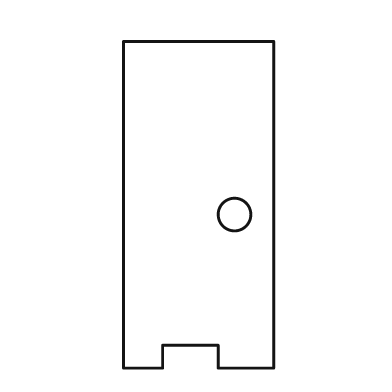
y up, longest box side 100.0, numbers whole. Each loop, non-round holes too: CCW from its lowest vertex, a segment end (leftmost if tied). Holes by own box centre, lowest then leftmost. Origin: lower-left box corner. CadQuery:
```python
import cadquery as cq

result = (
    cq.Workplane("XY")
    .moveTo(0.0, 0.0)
    .lineTo(12.0, 0.0)
    .lineTo(12.0, 7.0)
    .lineTo(29.0, 7.0)
    .lineTo(29.0, 0.0)
    .lineTo(46.0, 0.0)
    .lineTo(46.0, 100.0)
    .lineTo(0.0, 100.0)
    .close()
    .moveTo(34.0, 47.0)
    .circle(5.0)
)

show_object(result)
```